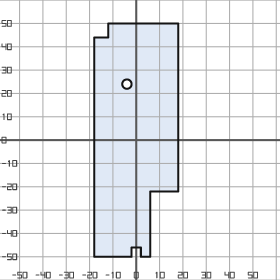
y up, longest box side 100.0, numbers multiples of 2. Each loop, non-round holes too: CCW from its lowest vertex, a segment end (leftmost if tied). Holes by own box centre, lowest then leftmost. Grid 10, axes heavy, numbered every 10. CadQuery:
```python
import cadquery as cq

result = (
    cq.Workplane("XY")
    .moveTo(-18.0, -50.0)
    .lineTo(-2.0, -50.0)
    .lineTo(-2.0, -46.0)
    .lineTo(2.0, -46.0)
    .lineTo(2.0, -50.0)
    .lineTo(6.0, -50.0)
    .lineTo(6.0, -22.0)
    .lineTo(18.0, -22.0)
    .lineTo(18.0, 50.0)
    .lineTo(-12.0, 50.0)
    .lineTo(-12.0, 44.0)
    .lineTo(-18.0, 44.0)
    .close()
    .moveTo(-4.0, 24.0)
    .circle(2.0)
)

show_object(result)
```